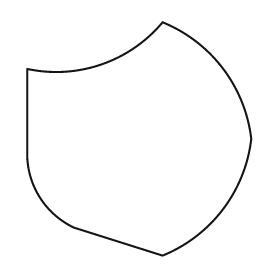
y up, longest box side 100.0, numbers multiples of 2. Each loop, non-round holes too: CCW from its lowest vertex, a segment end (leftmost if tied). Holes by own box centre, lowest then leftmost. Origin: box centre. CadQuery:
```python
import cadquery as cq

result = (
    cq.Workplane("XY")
    .moveTo(10.0, -50.0)
    .threePointArc((36.0, -30.0), (48.0, 0.0))
    .threePointArc((36.0, 30.0), (10.0, 50.0))
    .threePointArc((-16.0, 32.0), (-48.0, 30.0))
    .lineTo(-48.0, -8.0)
    .threePointArc((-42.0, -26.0), (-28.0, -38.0))
    .close()
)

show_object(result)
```